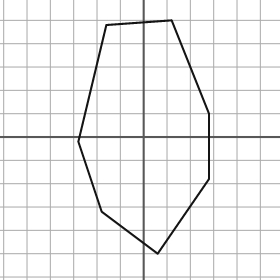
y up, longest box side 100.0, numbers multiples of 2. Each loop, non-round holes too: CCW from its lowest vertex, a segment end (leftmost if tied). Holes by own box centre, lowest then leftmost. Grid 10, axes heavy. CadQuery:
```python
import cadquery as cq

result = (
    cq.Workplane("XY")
    .moveTo(6.0, -50.0)
    .lineTo(28.0, -18.0)
    .lineTo(28.0, 10.0)
    .lineTo(12.0, 50.0)
    .lineTo(-16.0, 48.0)
    .lineTo(-28.0, -2.0)
    .lineTo(-18.0, -32.0)
    .close()
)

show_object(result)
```